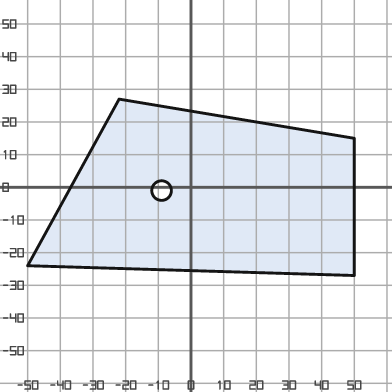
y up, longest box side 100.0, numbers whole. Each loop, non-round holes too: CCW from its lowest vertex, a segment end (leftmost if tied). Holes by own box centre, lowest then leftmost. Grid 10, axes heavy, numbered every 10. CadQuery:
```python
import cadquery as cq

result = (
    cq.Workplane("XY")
    .moveTo(50.0, -27.0)
    .lineTo(50.0, 15.0)
    .lineTo(-22.0, 27.0)
    .lineTo(-50.0, -24.0)
    .close()
    .moveTo(-9.0, -1.0)
    .circle(3.0)
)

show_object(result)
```